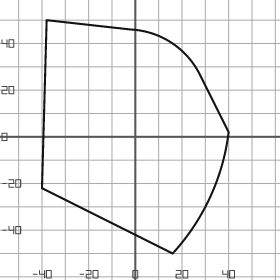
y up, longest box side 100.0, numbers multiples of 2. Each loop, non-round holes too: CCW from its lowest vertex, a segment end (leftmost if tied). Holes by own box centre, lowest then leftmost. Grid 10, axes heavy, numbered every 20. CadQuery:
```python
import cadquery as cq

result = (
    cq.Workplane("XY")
    .moveTo(16.0, -50.0)
    .threePointArc((32.0, -26.0), (40.0, 2.0))
    .lineTo(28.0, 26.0)
    .threePointArc((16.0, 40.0), (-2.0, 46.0))
    .lineTo(-38.0, 50.0)
    .lineTo(-40.0, -22.0)
    .close()
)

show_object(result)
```